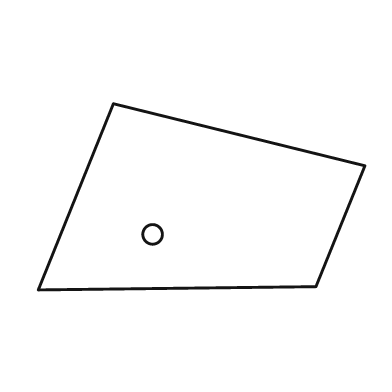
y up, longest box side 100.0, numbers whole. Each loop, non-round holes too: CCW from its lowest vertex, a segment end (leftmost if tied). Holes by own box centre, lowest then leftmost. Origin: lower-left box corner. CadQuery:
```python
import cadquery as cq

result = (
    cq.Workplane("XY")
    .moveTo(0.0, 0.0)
    .lineTo(85.0, 1.0)
    .lineTo(100.0, 38.0)
    .lineTo(23.0, 57.0)
    .close()
    .moveTo(35.0, 17.0)
    .circle(3.0)
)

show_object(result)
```